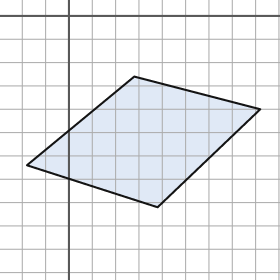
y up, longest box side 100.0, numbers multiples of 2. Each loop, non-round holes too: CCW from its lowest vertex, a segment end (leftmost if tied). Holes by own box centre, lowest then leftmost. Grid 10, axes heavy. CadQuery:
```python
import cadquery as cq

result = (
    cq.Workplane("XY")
    .moveTo(38.0, -82.0)
    .lineTo(82.0, -40.0)
    .lineTo(28.0, -26.0)
    .lineTo(-18.0, -64.0)
    .close()
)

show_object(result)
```